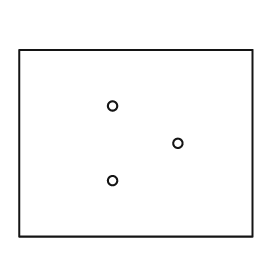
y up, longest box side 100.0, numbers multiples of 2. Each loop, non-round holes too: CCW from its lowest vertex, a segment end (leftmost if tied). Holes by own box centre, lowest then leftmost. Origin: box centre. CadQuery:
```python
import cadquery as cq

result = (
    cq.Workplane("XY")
    .moveTo(-50.0, -40.0)
    .lineTo(50.0, -40.0)
    .lineTo(50.0, 40.0)
    .lineTo(-50.0, 40.0)
    .close()
    .moveTo(-10.0, -16.0)
    .circle(2.0)
    .moveTo(18.0, 0.0)
    .circle(2.0)
    .moveTo(-10.0, 16.0)
    .circle(2.0)
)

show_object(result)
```